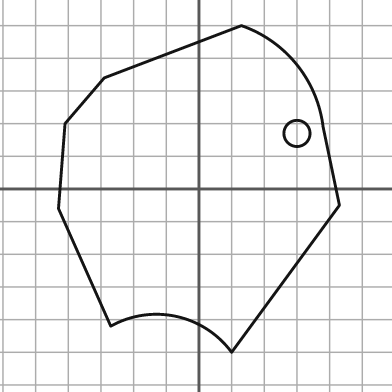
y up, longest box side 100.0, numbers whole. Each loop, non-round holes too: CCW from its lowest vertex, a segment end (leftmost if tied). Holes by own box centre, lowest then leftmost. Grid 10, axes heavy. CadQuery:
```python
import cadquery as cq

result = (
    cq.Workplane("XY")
    .moveTo(10.0, -50.0)
    .lineTo(43.0, -5.0)
    .lineTo(38.0, 19.0)
    .threePointArc((30.0, 38.0), (13.0, 50.0))
    .lineTo(-29.0, 34.0)
    .lineTo(-41.0, 20.0)
    .lineTo(-43.0, -6.0)
    .lineTo(-27.0, -42.0)
    .threePointArc((-7.0, -39.0), (10.0, -50.0))
    .close()
    .moveTo(30.0, 17.0)
    .circle(4.0)
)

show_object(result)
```